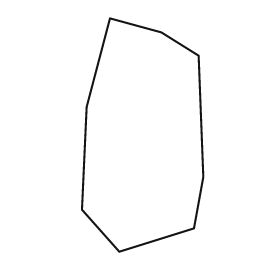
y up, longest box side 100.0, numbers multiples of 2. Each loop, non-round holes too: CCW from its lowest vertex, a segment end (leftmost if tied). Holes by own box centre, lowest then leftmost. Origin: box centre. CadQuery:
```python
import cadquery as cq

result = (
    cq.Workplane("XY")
    .moveTo(-10.0, -50.0)
    .lineTo(22.0, -40.0)
    .lineTo(26.0, -18.0)
    .lineTo(24.0, 34.0)
    .lineTo(8.0, 44.0)
    .lineTo(-14.0, 50.0)
    .lineTo(-24.0, 12.0)
    .lineTo(-26.0, -32.0)
    .close()
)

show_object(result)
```